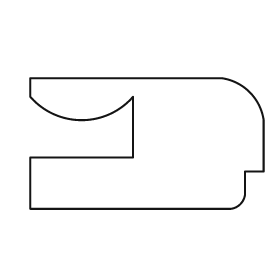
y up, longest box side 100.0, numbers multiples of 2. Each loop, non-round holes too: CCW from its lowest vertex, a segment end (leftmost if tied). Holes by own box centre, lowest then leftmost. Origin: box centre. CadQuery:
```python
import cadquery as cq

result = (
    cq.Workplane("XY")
    .moveTo(-50.0, -28.0)
    .lineTo(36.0, -28.0)
    .threePointArc((40.0, -26.0), (42.0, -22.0))
    .lineTo(42.0, -12.0)
    .lineTo(50.0, -12.0)
    .lineTo(50.0, 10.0)
    .threePointArc((44.0, 22.0), (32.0, 28.0))
    .lineTo(-50.0, 28.0)
    .lineTo(-50.0, 20.0)
    .threePointArc((-28.0, 10.0), (-6.0, 20.0))
    .lineTo(-6.0, -6.0)
    .lineTo(-50.0, -6.0)
    .close()
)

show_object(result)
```